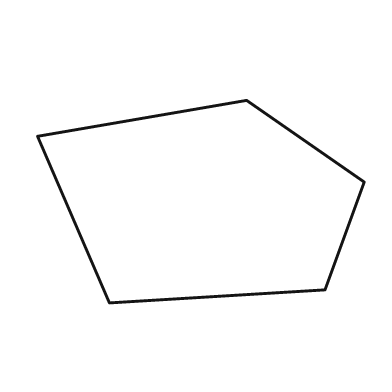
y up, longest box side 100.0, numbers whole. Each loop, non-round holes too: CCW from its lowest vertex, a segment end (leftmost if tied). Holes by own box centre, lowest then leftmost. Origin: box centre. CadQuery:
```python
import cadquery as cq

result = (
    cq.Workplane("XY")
    .moveTo(-28.0, -31.0)
    .lineTo(38.0, -27.0)
    .lineTo(50.0, 6.0)
    .lineTo(14.0, 31.0)
    .lineTo(-50.0, 20.0)
    .close()
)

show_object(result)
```